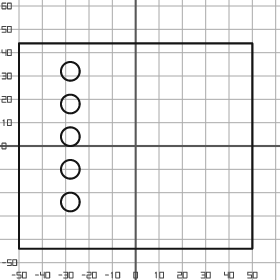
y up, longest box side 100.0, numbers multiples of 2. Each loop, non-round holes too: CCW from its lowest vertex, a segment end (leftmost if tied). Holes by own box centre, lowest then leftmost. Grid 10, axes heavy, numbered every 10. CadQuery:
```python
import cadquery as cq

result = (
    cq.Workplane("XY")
    .moveTo(-50.0, -44.0)
    .lineTo(50.0, -44.0)
    .lineTo(50.0, 44.0)
    .lineTo(-50.0, 44.0)
    .close()
    .moveTo(-28.0, -24.0)
    .circle(4.0)
    .moveTo(-28.0, -10.0)
    .circle(4.0)
    .moveTo(-28.0, 4.0)
    .circle(4.0)
    .moveTo(-28.0, 18.0)
    .circle(4.0)
    .moveTo(-28.0, 32.0)
    .circle(4.0)
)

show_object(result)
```